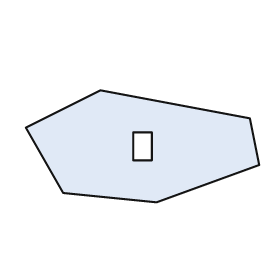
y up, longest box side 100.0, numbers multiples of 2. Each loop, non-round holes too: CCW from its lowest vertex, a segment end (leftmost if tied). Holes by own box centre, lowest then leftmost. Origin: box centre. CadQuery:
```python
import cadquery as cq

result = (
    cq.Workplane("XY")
    .moveTo(6.0, -24.0)
    .lineTo(50.0, -8.0)
    .lineTo(46.0, 12.0)
    .lineTo(-18.0, 24.0)
    .lineTo(-50.0, 8.0)
    .lineTo(-34.0, -20.0)
    .close()
    .moveTo(-4.0, -6.0)
    .lineTo(4.0, -6.0)
    .lineTo(4.0, 6.0)
    .lineTo(-4.0, 6.0)
    .close()
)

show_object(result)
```